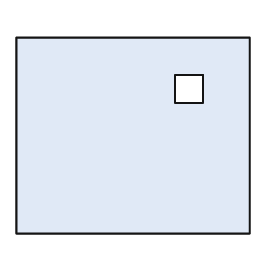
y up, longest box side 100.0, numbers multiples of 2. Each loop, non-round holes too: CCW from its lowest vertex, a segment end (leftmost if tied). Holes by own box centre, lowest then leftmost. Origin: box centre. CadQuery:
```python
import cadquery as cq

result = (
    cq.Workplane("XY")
    .moveTo(-50.0, -42.0)
    .lineTo(50.0, -42.0)
    .lineTo(50.0, 42.0)
    .lineTo(-50.0, 42.0)
    .close()
    .moveTo(18.0, 14.0)
    .lineTo(30.0, 14.0)
    .lineTo(30.0, 26.0)
    .lineTo(18.0, 26.0)
    .close()
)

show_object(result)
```